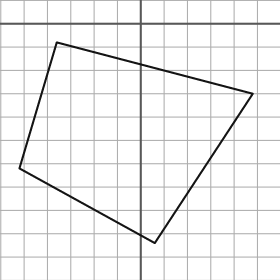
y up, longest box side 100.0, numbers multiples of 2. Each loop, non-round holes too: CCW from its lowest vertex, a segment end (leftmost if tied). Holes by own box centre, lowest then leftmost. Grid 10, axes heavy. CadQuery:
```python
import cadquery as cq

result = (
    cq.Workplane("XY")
    .moveTo(6.0, -94.0)
    .lineTo(48.0, -30.0)
    .lineTo(-36.0, -8.0)
    .lineTo(-52.0, -62.0)
    .close()
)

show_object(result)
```